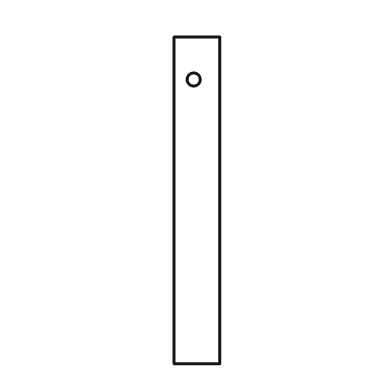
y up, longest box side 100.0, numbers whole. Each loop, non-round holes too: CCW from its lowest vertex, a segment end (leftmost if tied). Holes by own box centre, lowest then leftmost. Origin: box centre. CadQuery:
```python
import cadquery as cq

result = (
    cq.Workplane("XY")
    .moveTo(-7.0, -50.0)
    .lineTo(7.0, -50.0)
    .lineTo(7.0, 50.0)
    .lineTo(-7.0, 50.0)
    .close()
    .moveTo(-1.0, 37.0)
    .circle(2.0)
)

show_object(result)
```